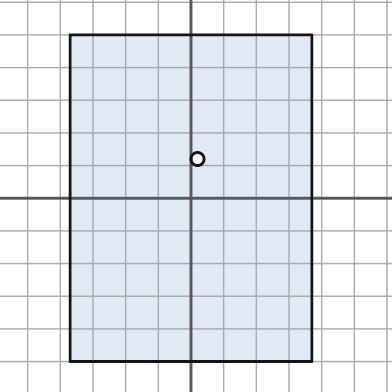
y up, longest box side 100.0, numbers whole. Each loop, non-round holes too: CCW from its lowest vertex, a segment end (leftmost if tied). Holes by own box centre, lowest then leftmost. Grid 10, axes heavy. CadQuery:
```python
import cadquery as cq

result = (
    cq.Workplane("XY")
    .moveTo(-37.0, -50.0)
    .lineTo(37.0, -50.0)
    .lineTo(37.0, 50.0)
    .lineTo(-37.0, 50.0)
    .close()
    .moveTo(2.0, 12.0)
    .circle(2.0)
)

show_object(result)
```